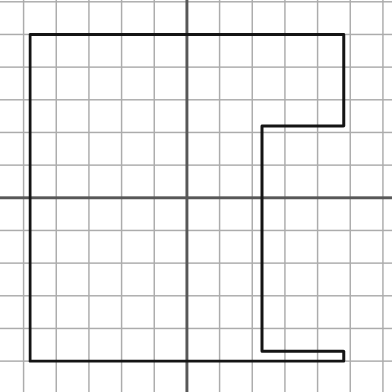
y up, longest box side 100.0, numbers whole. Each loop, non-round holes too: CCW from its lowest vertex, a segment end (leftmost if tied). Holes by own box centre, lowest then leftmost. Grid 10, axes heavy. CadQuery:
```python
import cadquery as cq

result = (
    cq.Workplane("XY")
    .moveTo(-48.0, -50.0)
    .lineTo(48.0, -50.0)
    .lineTo(48.0, -47.0)
    .lineTo(23.0, -47.0)
    .lineTo(23.0, 22.0)
    .lineTo(48.0, 22.0)
    .lineTo(48.0, 50.0)
    .lineTo(-48.0, 50.0)
    .close()
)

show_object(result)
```